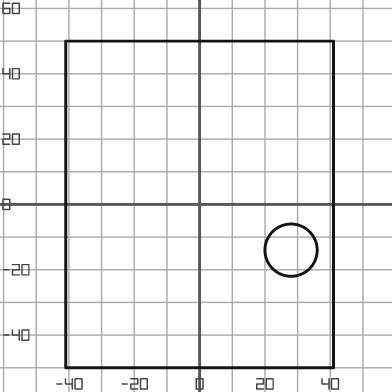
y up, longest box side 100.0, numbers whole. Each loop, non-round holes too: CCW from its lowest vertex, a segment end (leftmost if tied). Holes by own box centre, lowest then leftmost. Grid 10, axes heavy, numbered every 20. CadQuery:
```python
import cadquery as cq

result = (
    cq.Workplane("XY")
    .moveTo(-41.0, -50.0)
    .lineTo(41.0, -50.0)
    .lineTo(41.0, 50.0)
    .lineTo(-41.0, 50.0)
    .close()
    .moveTo(28.0, -14.0)
    .circle(8.0)
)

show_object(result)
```